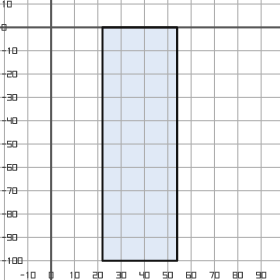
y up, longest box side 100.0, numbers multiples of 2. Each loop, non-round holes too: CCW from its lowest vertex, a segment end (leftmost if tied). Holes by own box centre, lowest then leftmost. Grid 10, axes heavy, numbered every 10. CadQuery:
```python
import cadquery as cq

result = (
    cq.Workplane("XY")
    .moveTo(22.0, -100.0)
    .lineTo(54.0, -100.0)
    .lineTo(54.0, 0.0)
    .lineTo(22.0, 0.0)
    .close()
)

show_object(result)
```